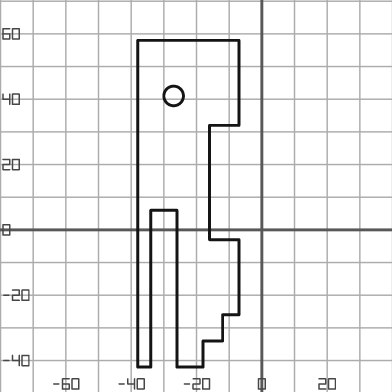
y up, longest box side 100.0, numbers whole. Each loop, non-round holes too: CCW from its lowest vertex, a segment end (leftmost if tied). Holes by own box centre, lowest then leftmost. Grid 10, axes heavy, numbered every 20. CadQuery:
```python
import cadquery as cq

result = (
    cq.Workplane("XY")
    .moveTo(-38.0, -42.0)
    .lineTo(-34.0, -42.0)
    .lineTo(-34.0, 6.0)
    .lineTo(-26.0, 6.0)
    .lineTo(-26.0, -42.0)
    .lineTo(-18.0, -42.0)
    .lineTo(-18.0, -34.0)
    .lineTo(-12.0, -34.0)
    .lineTo(-12.0, -26.0)
    .lineTo(-7.0, -26.0)
    .lineTo(-7.0, -3.0)
    .lineTo(-16.0, -3.0)
    .lineTo(-16.0, 32.0)
    .lineTo(-7.0, 32.0)
    .lineTo(-7.0, 58.0)
    .lineTo(-38.0, 58.0)
    .close()
    .moveTo(-27.0, 41.0)
    .circle(3.0)
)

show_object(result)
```